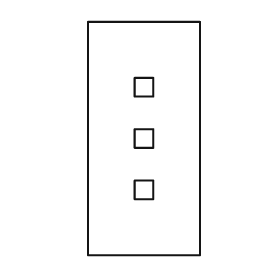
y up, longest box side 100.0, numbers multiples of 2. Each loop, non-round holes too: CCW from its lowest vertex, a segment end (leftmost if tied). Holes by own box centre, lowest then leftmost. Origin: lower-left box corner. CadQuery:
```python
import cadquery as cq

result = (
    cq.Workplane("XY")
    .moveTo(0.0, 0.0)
    .lineTo(48.0, 0.0)
    .lineTo(48.0, 100.0)
    .lineTo(0.0, 100.0)
    .close()
    .moveTo(20.0, 24.0)
    .lineTo(28.0, 24.0)
    .lineTo(28.0, 32.0)
    .lineTo(20.0, 32.0)
    .close()
    .moveTo(20.0, 46.0)
    .lineTo(28.0, 46.0)
    .lineTo(28.0, 54.0)
    .lineTo(20.0, 54.0)
    .close()
    .moveTo(20.0, 68.0)
    .lineTo(28.0, 68.0)
    .lineTo(28.0, 76.0)
    .lineTo(20.0, 76.0)
    .close()
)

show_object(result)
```